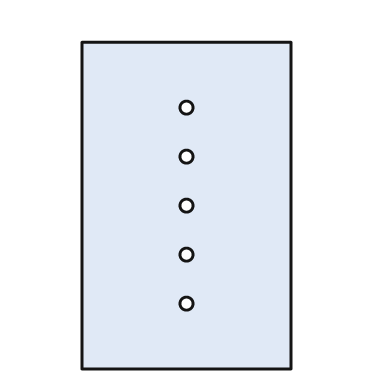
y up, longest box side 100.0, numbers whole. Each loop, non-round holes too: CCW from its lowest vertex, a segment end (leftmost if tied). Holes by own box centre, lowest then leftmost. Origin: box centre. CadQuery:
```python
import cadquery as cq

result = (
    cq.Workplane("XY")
    .moveTo(-32.0, -50.0)
    .lineTo(32.0, -50.0)
    .lineTo(32.0, 50.0)
    .lineTo(-32.0, 50.0)
    .close()
    .moveTo(0.0, -30.0)
    .circle(2.0)
    .moveTo(0.0, -15.0)
    .circle(2.0)
    .moveTo(0.0, 0.0)
    .circle(2.0)
    .moveTo(0.0, 15.0)
    .circle(2.0)
    .moveTo(0.0, 30.0)
    .circle(2.0)
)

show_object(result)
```